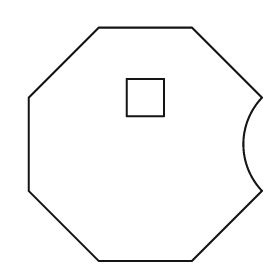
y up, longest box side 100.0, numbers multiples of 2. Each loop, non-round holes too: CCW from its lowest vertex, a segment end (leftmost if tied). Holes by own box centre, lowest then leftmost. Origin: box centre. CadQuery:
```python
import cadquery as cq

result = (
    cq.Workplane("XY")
    .moveTo(-20.0, -50.0)
    .lineTo(20.0, -50.0)
    .lineTo(50.0, -20.0)
    .threePointArc((42.0, 0.0), (50.0, 20.0))
    .lineTo(20.0, 50.0)
    .lineTo(-20.0, 50.0)
    .lineTo(-50.0, 20.0)
    .lineTo(-50.0, -20.0)
    .close()
    .moveTo(-8.0, 12.0)
    .lineTo(8.0, 12.0)
    .lineTo(8.0, 28.0)
    .lineTo(-8.0, 28.0)
    .close()
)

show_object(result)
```